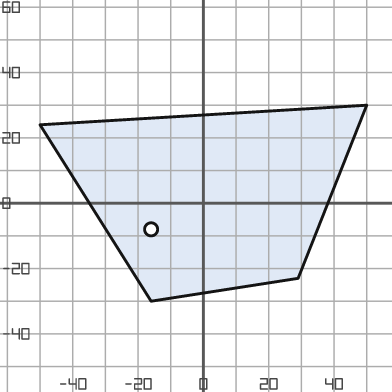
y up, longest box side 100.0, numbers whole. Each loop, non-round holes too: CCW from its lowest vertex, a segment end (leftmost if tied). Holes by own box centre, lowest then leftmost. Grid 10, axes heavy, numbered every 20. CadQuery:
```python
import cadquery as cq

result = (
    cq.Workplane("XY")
    .moveTo(-16.0, -30.0)
    .lineTo(29.0, -23.0)
    .lineTo(50.0, 30.0)
    .lineTo(-50.0, 24.0)
    .close()
    .moveTo(-16.0, -8.0)
    .circle(2.0)
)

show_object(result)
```